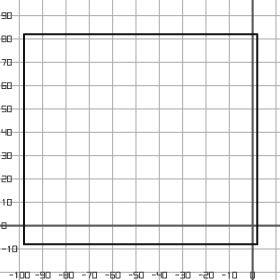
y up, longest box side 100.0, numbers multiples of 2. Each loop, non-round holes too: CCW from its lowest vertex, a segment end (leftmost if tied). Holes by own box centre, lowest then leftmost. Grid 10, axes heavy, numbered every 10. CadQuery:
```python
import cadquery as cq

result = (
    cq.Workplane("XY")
    .moveTo(-98.0, -8.0)
    .lineTo(2.0, -8.0)
    .lineTo(2.0, 82.0)
    .lineTo(-98.0, 82.0)
    .close()
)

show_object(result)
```